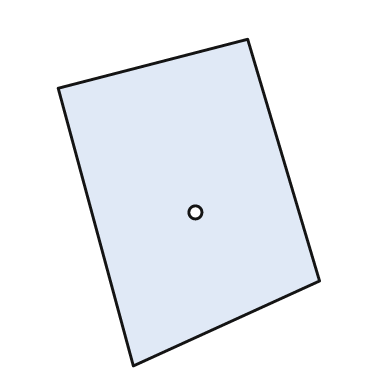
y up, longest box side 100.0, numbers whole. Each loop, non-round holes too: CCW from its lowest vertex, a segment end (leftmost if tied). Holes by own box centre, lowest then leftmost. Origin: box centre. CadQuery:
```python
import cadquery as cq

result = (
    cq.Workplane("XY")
    .moveTo(-17.0, -50.0)
    .lineTo(40.0, -24.0)
    .lineTo(18.0, 50.0)
    .lineTo(-40.0, 35.0)
    .close()
    .moveTo(2.0, -3.0)
    .circle(2.0)
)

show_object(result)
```